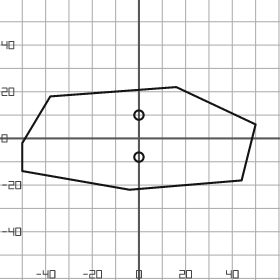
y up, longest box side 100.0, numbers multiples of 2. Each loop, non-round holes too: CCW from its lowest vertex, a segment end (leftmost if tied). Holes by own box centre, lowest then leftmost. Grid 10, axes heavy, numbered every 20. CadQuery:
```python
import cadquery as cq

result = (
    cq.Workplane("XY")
    .moveTo(-4.0, -22.0)
    .lineTo(44.0, -18.0)
    .lineTo(50.0, 6.0)
    .lineTo(16.0, 22.0)
    .lineTo(-38.0, 18.0)
    .lineTo(-50.0, -2.0)
    .lineTo(-50.0, -14.0)
    .close()
    .moveTo(0.0, -8.0)
    .circle(2.0)
    .moveTo(0.0, 10.0)
    .circle(2.0)
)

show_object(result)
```